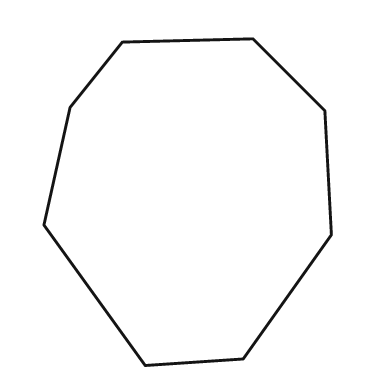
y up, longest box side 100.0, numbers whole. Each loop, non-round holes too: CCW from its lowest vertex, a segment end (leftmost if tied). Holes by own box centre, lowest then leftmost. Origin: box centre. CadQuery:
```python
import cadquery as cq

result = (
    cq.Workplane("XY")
    .moveTo(-13.0, -50.0)
    .lineTo(17.0, -48.0)
    .lineTo(44.0, -10.0)
    .lineTo(42.0, 28.0)
    .lineTo(20.0, 50.0)
    .lineTo(-20.0, 49.0)
    .lineTo(-36.0, 29.0)
    .lineTo(-44.0, -7.0)
    .close()
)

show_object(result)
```